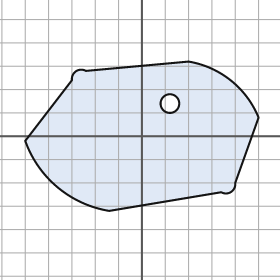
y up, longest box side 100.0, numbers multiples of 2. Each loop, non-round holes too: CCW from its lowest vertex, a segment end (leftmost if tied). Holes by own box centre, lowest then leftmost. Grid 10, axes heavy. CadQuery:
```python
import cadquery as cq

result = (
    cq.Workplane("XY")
    .moveTo(-14.0, -32.0)
    .lineTo(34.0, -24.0)
    .threePointArc((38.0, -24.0), (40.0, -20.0))
    .lineTo(50.0, 8.0)
    .threePointArc((38.0, 24.0), (20.0, 32.0))
    .lineTo(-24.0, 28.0)
    .threePointArc((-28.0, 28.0), (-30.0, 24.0))
    .lineTo(-50.0, -2.0)
    .threePointArc((-36.0, -22.0), (-14.0, -32.0))
    .close()
    .moveTo(12.0, 14.0)
    .circle(4.0)
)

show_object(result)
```